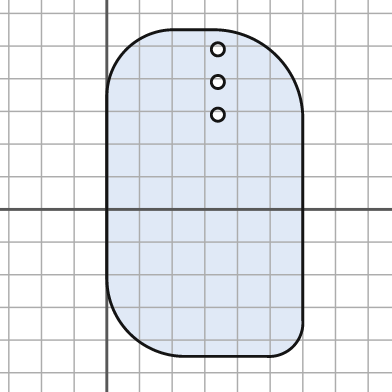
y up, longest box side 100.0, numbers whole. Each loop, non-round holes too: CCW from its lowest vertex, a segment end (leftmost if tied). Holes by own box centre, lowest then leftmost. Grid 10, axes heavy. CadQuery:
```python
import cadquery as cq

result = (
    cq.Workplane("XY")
    .moveTo(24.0, -45.0)
    .lineTo(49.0, -45.0)
    .threePointArc((57.0, -42.0), (60.0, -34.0))
    .lineTo(60.0, 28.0)
    .threePointArc((52.0, 47.0), (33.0, 55.0))
    .lineTo(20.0, 55.0)
    .threePointArc((6.0, 49.0), (0.0, 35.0))
    .lineTo(0.0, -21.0)
    .threePointArc((7.0, -38.0), (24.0, -45.0))
    .close()
    .moveTo(34.0, 29.0)
    .circle(2.0)
    .moveTo(34.0, 39.0)
    .circle(2.0)
    .moveTo(34.0, 49.0)
    .circle(2.0)
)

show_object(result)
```